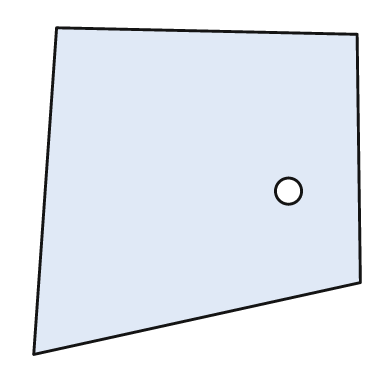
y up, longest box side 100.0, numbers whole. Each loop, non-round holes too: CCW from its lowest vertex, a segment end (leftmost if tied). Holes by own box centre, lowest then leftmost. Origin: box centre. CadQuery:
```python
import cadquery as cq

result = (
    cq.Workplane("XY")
    .moveTo(-50.0, -50.0)
    .lineTo(50.0, -28.0)
    .lineTo(49.0, 48.0)
    .lineTo(-43.0, 50.0)
    .close()
    .moveTo(28.0, 0.0)
    .circle(4.0)
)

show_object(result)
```